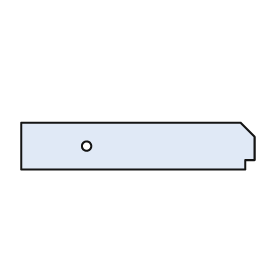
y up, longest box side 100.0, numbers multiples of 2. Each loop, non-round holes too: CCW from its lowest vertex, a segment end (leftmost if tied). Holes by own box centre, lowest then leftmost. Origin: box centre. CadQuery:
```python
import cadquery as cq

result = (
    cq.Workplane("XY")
    .moveTo(-50.0, -10.0)
    .lineTo(46.0, -10.0)
    .lineTo(46.0, -6.0)
    .lineTo(50.0, -6.0)
    .lineTo(50.0, 4.0)
    .lineTo(44.0, 10.0)
    .lineTo(-50.0, 10.0)
    .close()
    .moveTo(-22.0, 0.0)
    .circle(2.0)
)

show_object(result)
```